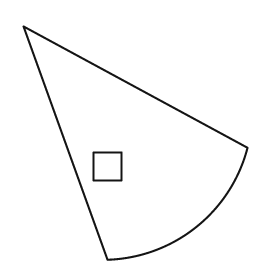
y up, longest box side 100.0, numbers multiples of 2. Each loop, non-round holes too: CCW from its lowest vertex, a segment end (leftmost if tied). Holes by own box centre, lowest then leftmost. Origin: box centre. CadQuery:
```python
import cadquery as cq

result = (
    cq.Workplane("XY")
    .moveTo(-12.0, -50.0)
    .threePointArc((26.0, -36.0), (48.0, -2.0))
    .lineTo(-48.0, 50.0)
    .close()
    .moveTo(-18.0, -16.0)
    .lineTo(-6.0, -16.0)
    .lineTo(-6.0, -4.0)
    .lineTo(-18.0, -4.0)
    .close()
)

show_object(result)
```